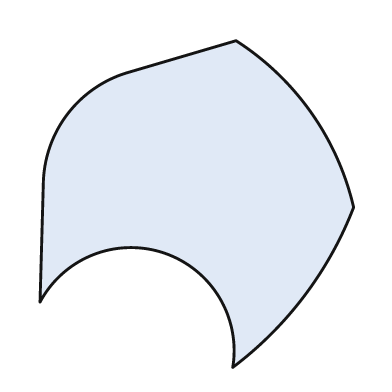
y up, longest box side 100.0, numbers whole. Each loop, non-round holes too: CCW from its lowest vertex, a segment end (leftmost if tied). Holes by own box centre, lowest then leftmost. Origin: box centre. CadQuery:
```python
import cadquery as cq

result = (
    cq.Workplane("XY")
    .moveTo(11.0, -50.0)
    .threePointArc((33.0, -28.0), (48.0, -1.0))
    .threePointArc((35.0, 28.0), (12.0, 50.0))
    .lineTo(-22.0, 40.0)
    .threePointArc((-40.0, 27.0), (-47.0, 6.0))
    .lineTo(-48.0, -30.0)
    .threePointArc((-10.0, -15.0), (11.0, -50.0))
    .close()
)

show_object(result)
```